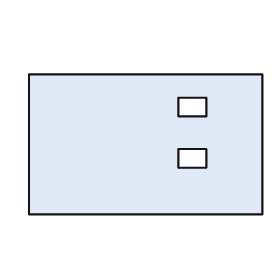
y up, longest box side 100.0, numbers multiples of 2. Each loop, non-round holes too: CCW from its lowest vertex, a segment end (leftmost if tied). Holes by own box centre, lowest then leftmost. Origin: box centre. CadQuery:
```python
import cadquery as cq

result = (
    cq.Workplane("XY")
    .moveTo(-50.0, -30.0)
    .lineTo(50.0, -30.0)
    .lineTo(50.0, 30.0)
    .lineTo(-50.0, 30.0)
    .close()
    .moveTo(14.0, -10.0)
    .lineTo(26.0, -10.0)
    .lineTo(26.0, -2.0)
    .lineTo(14.0, -2.0)
    .close()
    .moveTo(14.0, 12.0)
    .lineTo(26.0, 12.0)
    .lineTo(26.0, 20.0)
    .lineTo(14.0, 20.0)
    .close()
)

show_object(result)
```